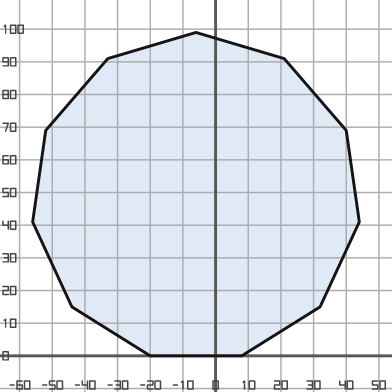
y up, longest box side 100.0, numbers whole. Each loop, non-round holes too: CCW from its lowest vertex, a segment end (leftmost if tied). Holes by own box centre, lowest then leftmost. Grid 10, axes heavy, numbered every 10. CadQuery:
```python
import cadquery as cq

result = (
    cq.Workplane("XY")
    .moveTo(-20.0, 0.0)
    .lineTo(8.0, 0.0)
    .lineTo(32.0, 15.0)
    .lineTo(44.0, 41.0)
    .lineTo(40.0, 69.0)
    .lineTo(21.0, 91.0)
    .lineTo(-6.0, 99.0)
    .lineTo(-33.0, 91.0)
    .lineTo(-52.0, 69.0)
    .lineTo(-56.0, 41.0)
    .lineTo(-44.0, 15.0)
    .close()
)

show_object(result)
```